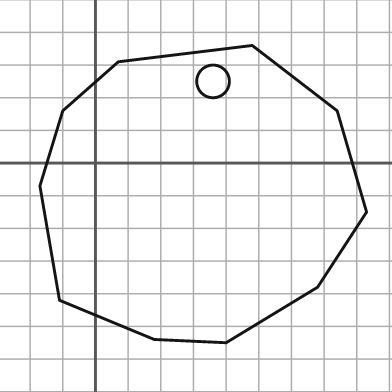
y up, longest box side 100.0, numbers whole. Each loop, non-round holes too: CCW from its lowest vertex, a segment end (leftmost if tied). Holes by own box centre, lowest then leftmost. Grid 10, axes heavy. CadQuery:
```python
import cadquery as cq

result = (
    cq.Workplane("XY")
    .moveTo(40.0, -55.0)
    .lineTo(68.0, -38.0)
    .lineTo(83.0, -15.0)
    .lineTo(74.0, 16.0)
    .lineTo(48.0, 36.0)
    .lineTo(7.0, 31.0)
    .lineTo(-10.0, 16.0)
    .lineTo(-17.0, -7.0)
    .lineTo(-11.0, -42.0)
    .lineTo(18.0, -54.0)
    .close()
    .moveTo(36.0, 25.0)
    .circle(5.0)
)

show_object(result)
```